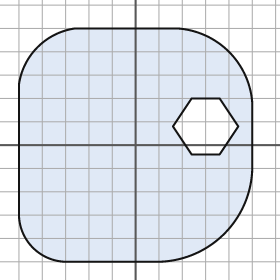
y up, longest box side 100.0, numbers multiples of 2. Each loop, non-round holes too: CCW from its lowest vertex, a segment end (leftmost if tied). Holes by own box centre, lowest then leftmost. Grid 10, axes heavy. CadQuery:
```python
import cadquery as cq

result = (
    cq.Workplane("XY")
    .moveTo(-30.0, -50.0)
    .lineTo(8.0, -50.0)
    .threePointArc((38.0, -38.0), (50.0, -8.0))
    .lineTo(50.0, 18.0)
    .threePointArc((40.0, 40.0), (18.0, 50.0))
    .lineTo(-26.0, 50.0)
    .threePointArc((-42.0, 42.0), (-50.0, 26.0))
    .lineTo(-50.0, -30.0)
    .threePointArc((-44.0, -44.0), (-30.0, -50.0))
    .close()
    .moveTo(24.0, -4.0)
    .lineTo(36.0, -4.0)
    .lineTo(44.0, 8.0)
    .lineTo(36.0, 20.0)
    .lineTo(24.0, 20.0)
    .lineTo(16.0, 8.0)
    .close()
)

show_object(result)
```